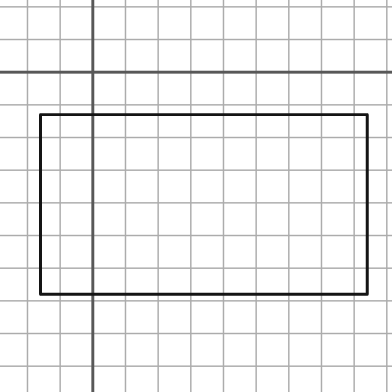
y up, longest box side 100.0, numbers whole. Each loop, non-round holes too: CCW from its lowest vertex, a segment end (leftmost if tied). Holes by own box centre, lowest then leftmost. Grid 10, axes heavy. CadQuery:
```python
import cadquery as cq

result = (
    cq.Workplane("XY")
    .moveTo(-16.0, -68.0)
    .lineTo(84.0, -68.0)
    .lineTo(84.0, -13.0)
    .lineTo(-16.0, -13.0)
    .close()
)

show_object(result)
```